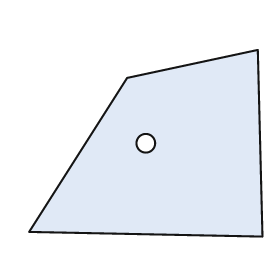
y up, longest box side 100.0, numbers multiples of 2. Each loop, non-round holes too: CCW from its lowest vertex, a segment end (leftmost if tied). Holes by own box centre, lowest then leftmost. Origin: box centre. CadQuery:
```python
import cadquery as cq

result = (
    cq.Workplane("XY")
    .moveTo(50.0, -40.0)
    .lineTo(48.0, 40.0)
    .lineTo(-8.0, 28.0)
    .lineTo(-50.0, -38.0)
    .close()
    .moveTo(0.0, 0.0)
    .circle(4.0)
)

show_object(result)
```